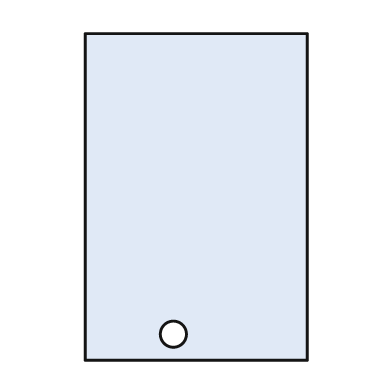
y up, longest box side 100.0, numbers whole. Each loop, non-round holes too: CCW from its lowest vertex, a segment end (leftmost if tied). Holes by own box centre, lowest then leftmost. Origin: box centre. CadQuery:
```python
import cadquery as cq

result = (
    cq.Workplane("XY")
    .moveTo(-34.0, -50.0)
    .lineTo(34.0, -50.0)
    .lineTo(34.0, 50.0)
    .lineTo(-34.0, 50.0)
    .close()
    .moveTo(-7.0, -42.0)
    .circle(4.0)
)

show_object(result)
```